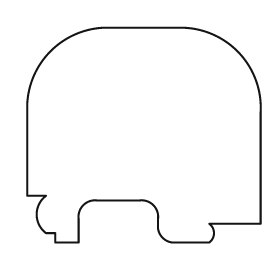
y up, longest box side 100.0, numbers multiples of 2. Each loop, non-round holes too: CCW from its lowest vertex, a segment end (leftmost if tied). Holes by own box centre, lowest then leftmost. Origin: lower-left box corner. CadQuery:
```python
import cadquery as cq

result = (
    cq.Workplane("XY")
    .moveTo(12.0, 0.0)
    .lineTo(22.0, 0.0)
    .lineTo(22.0, 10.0)
    .threePointArc((24.0, 16.0), (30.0, 18.0))
    .lineTo(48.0, 18.0)
    .threePointArc((54.0, 16.0), (56.0, 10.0))
    .lineTo(56.0, 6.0)
    .threePointArc((58.0, 2.0), (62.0, 0.0))
    .lineTo(78.0, 0.0)
    .threePointArc((80.0, 4.0), (78.0, 8.0))
    .lineTo(100.0, 8.0)
    .lineTo(100.0, 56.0)
    .threePointArc((90.0, 82.0), (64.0, 92.0))
    .lineTo(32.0, 92.0)
    .threePointArc((10.0, 82.0), (0.0, 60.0))
    .lineTo(0.0, 20.0)
    .lineTo(8.0, 20.0)
    .threePointArc((4.0, 12.0), (8.0, 4.0))
    .lineTo(12.0, 4.0)
    .close()
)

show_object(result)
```